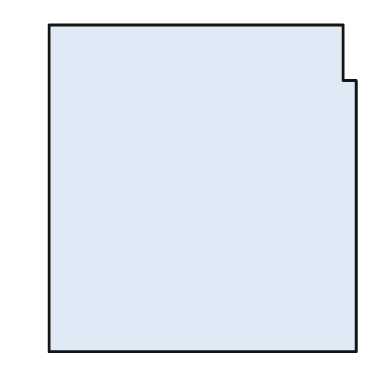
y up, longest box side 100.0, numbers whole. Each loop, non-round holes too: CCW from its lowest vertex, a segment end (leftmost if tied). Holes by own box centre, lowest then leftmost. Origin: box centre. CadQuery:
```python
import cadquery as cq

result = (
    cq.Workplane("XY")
    .moveTo(-47.0, -50.0)
    .lineTo(47.0, -50.0)
    .lineTo(47.0, 33.0)
    .lineTo(43.0, 33.0)
    .lineTo(43.0, 50.0)
    .lineTo(-47.0, 50.0)
    .close()
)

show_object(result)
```